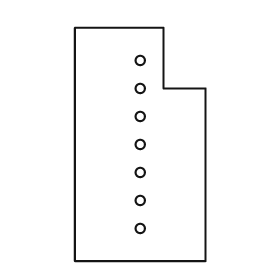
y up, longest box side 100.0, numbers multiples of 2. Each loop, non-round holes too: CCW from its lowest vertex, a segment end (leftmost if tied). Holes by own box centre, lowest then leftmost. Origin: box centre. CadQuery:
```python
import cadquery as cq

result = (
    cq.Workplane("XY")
    .moveTo(-28.0, -50.0)
    .lineTo(28.0, -50.0)
    .lineTo(28.0, 24.0)
    .lineTo(10.0, 24.0)
    .lineTo(10.0, 50.0)
    .lineTo(-28.0, 50.0)
    .close()
    .moveTo(0.0, -36.0)
    .circle(2.0)
    .moveTo(0.0, -24.0)
    .circle(2.0)
    .moveTo(0.0, -12.0)
    .circle(2.0)
    .moveTo(0.0, 0.0)
    .circle(2.0)
    .moveTo(0.0, 12.0)
    .circle(2.0)
    .moveTo(0.0, 24.0)
    .circle(2.0)
    .moveTo(0.0, 36.0)
    .circle(2.0)
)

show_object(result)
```